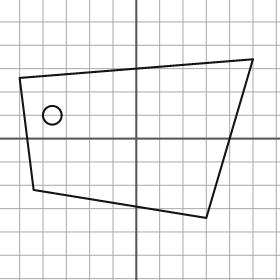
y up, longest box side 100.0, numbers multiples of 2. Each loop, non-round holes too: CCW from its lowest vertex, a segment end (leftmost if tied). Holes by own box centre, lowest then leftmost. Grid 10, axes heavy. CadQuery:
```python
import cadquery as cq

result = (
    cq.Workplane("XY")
    .moveTo(30.0, -34.0)
    .lineTo(50.0, 34.0)
    .lineTo(-50.0, 26.0)
    .lineTo(-44.0, -22.0)
    .close()
    .moveTo(-36.0, 10.0)
    .circle(4.0)
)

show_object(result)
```